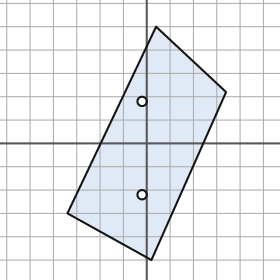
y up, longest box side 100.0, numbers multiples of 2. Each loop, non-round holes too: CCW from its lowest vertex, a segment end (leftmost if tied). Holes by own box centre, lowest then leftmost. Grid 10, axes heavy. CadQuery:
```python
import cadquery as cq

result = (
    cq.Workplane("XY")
    .moveTo(2.0, -50.0)
    .lineTo(34.0, 22.0)
    .lineTo(4.0, 50.0)
    .lineTo(-34.0, -30.0)
    .close()
    .moveTo(-2.0, -22.0)
    .circle(2.0)
    .moveTo(-2.0, 18.0)
    .circle(2.0)
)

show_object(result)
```